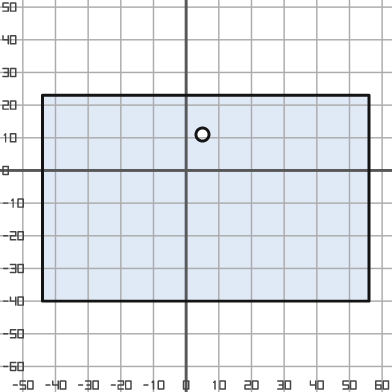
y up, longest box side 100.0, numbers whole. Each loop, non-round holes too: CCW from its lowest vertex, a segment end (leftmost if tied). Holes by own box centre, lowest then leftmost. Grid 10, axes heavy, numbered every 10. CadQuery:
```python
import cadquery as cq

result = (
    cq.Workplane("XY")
    .moveTo(-44.0, -40.0)
    .lineTo(56.0, -40.0)
    .lineTo(56.0, 23.0)
    .lineTo(-44.0, 23.0)
    .close()
    .moveTo(5.0, 11.0)
    .circle(2.0)
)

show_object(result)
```